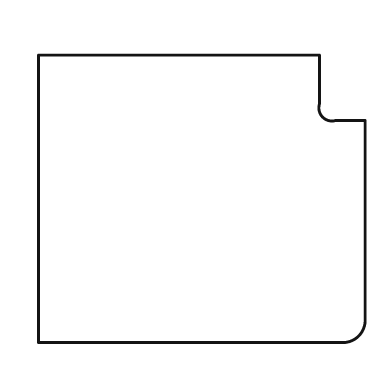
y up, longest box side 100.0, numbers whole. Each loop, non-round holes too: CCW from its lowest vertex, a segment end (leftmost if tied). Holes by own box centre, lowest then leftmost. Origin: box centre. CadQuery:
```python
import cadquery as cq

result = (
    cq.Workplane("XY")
    .moveTo(-50.0, -44.0)
    .lineTo(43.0, -44.0)
    .threePointArc((48.0, -42.0), (50.0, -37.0))
    .lineTo(50.0, 24.0)
    .lineTo(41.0, 24.0)
    .threePointArc((37.0, 25.0), (36.0, 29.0))
    .lineTo(36.0, 44.0)
    .lineTo(-50.0, 44.0)
    .close()
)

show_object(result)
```